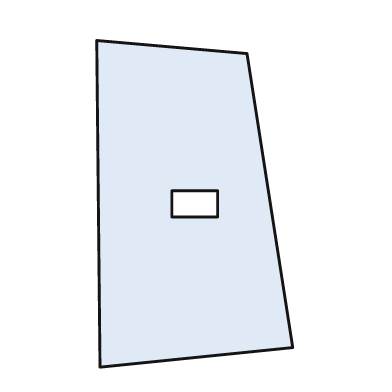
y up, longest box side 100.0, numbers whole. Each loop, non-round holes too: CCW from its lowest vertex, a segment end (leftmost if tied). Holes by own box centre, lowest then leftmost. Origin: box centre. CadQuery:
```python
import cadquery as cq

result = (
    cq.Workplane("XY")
    .moveTo(-29.0, -50.0)
    .lineTo(30.0, -44.0)
    .lineTo(16.0, 46.0)
    .lineTo(-30.0, 50.0)
    .close()
    .moveTo(-7.0, -4.0)
    .lineTo(7.0, -4.0)
    .lineTo(7.0, 4.0)
    .lineTo(-7.0, 4.0)
    .close()
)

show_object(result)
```